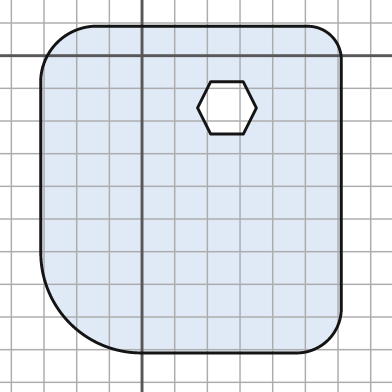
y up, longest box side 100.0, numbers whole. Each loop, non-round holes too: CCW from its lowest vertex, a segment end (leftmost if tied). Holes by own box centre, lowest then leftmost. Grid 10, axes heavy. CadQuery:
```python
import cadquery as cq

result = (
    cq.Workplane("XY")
    .moveTo(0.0, -91.0)
    .lineTo(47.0, -91.0)
    .threePointArc((57.0, -87.0), (61.0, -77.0))
    .lineTo(61.0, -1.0)
    .threePointArc((58.0, 6.0), (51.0, 9.0))
    .lineTo(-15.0, 9.0)
    .threePointArc((-26.0, 4.0), (-31.0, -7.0))
    .lineTo(-31.0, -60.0)
    .threePointArc((-22.0, -82.0), (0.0, -91.0))
    .close()
    .moveTo(21.0, -24.0)
    .lineTo(31.0, -24.0)
    .lineTo(35.0, -16.0)
    .lineTo(31.0, -8.0)
    .lineTo(21.0, -8.0)
    .lineTo(17.0, -16.0)
    .close()
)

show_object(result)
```